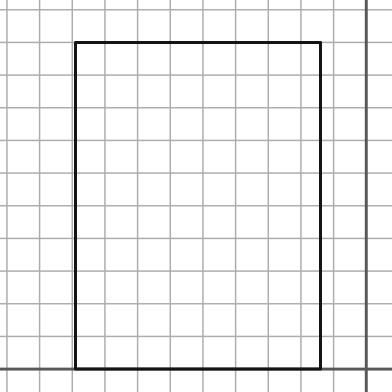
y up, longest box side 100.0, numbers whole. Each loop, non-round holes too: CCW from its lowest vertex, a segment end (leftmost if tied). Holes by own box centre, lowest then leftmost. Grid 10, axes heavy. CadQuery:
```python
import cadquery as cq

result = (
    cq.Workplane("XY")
    .moveTo(-89.0, 0.0)
    .lineTo(-14.0, 0.0)
    .lineTo(-14.0, 100.0)
    .lineTo(-89.0, 100.0)
    .close()
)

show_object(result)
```